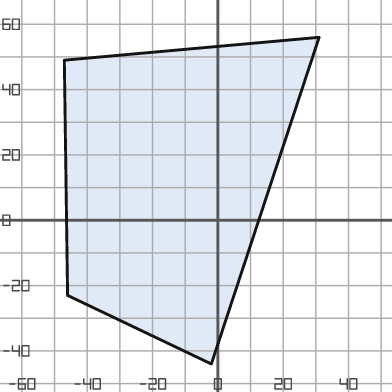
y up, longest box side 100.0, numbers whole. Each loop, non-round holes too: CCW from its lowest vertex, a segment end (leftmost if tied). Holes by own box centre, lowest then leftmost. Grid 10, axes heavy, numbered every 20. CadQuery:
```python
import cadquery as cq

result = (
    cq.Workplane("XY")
    .moveTo(-2.0, -44.0)
    .lineTo(31.0, 56.0)
    .lineTo(-47.0, 49.0)
    .lineTo(-46.0, -23.0)
    .close()
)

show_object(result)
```